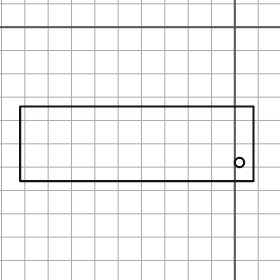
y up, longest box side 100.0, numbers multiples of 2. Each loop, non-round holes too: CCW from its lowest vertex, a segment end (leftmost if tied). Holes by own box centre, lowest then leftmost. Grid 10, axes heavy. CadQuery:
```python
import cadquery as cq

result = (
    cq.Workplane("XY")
    .moveTo(-92.0, -66.0)
    .lineTo(8.0, -66.0)
    .lineTo(8.0, -34.0)
    .lineTo(-92.0, -34.0)
    .close()
    .moveTo(2.0, -58.0)
    .circle(2.0)
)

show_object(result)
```